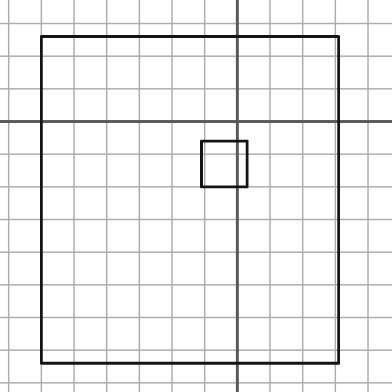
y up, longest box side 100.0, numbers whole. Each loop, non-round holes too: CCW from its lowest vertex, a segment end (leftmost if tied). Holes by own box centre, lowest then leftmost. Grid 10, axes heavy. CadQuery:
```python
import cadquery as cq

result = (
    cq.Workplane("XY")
    .moveTo(-60.0, -74.0)
    .lineTo(31.0, -74.0)
    .lineTo(31.0, 26.0)
    .lineTo(-60.0, 26.0)
    .close()
    .moveTo(-11.0, -20.0)
    .lineTo(3.0, -20.0)
    .lineTo(3.0, -6.0)
    .lineTo(-11.0, -6.0)
    .close()
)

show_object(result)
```